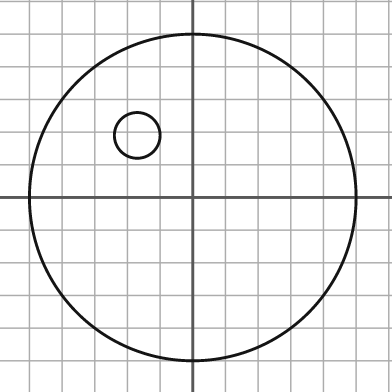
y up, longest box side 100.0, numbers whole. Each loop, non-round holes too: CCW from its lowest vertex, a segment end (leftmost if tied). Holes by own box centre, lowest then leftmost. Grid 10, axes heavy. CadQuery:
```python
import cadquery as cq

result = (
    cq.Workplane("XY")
    .moveTo(0.0, 0.0)
    .circle(50.0)
    .moveTo(-17.0, 19.0)
    .circle(7.0)
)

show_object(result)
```